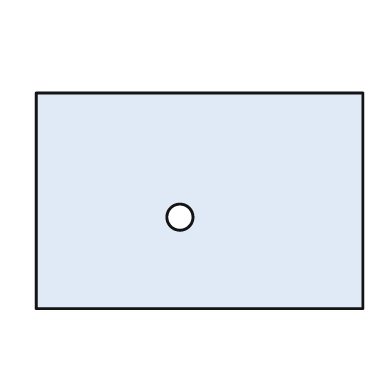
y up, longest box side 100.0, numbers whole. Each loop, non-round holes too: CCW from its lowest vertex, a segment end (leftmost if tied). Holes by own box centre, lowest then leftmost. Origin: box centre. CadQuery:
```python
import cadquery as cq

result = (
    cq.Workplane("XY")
    .moveTo(-50.0, -33.0)
    .lineTo(50.0, -33.0)
    .lineTo(50.0, 33.0)
    .lineTo(-50.0, 33.0)
    .close()
    .moveTo(-6.0, -5.0)
    .circle(4.0)
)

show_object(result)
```